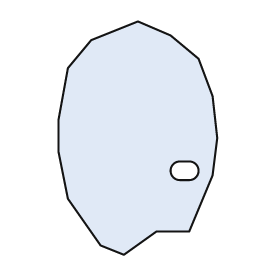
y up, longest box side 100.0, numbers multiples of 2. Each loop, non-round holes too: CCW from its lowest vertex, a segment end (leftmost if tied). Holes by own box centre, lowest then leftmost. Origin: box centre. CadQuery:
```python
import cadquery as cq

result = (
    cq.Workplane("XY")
    .moveTo(-6.0, -50.0)
    .lineTo(8.0, -40.0)
    .lineTo(22.0, -40.0)
    .lineTo(32.0, -16.0)
    .lineTo(34.0, 0.0)
    .lineTo(32.0, 18.0)
    .lineTo(26.0, 34.0)
    .lineTo(14.0, 44.0)
    .lineTo(0.0, 50.0)
    .lineTo(-20.0, 42.0)
    .lineTo(-30.0, 30.0)
    .lineTo(-34.0, 8.0)
    .lineTo(-34.0, -6.0)
    .lineTo(-30.0, -26.0)
    .lineTo(-16.0, -46.0)
    .close()
    .moveTo(18.0, -18.0)
    .lineTo(22.0, -18.0)
    .threePointArc((26.0, -14.0), (22.0, -10.0))
    .lineTo(18.0, -10.0)
    .threePointArc((14.0, -14.0), (18.0, -18.0))
    .close()
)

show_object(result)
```